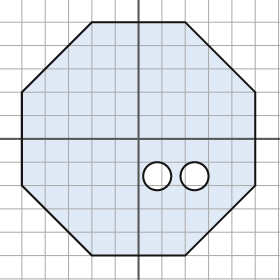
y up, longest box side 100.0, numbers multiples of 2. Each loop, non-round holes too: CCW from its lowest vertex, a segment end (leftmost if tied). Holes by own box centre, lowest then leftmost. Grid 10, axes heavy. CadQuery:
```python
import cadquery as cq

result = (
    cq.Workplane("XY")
    .moveTo(-20.0, -50.0)
    .lineTo(20.0, -50.0)
    .lineTo(50.0, -20.0)
    .lineTo(50.0, 20.0)
    .lineTo(20.0, 50.0)
    .lineTo(-20.0, 50.0)
    .lineTo(-50.0, 20.0)
    .lineTo(-50.0, -20.0)
    .close()
    .moveTo(8.0, -16.0)
    .circle(6.0)
    .moveTo(24.0, -16.0)
    .circle(6.0)
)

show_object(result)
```